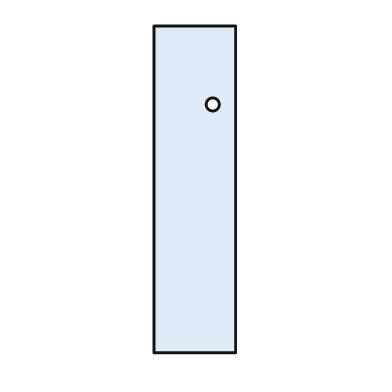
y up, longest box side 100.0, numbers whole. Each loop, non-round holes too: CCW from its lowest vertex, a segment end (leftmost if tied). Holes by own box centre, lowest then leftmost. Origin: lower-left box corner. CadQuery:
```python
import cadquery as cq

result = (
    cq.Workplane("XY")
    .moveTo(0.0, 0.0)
    .lineTo(25.0, 0.0)
    .lineTo(25.0, 100.0)
    .lineTo(0.0, 100.0)
    .close()
    .moveTo(18.0, 76.0)
    .circle(2.0)
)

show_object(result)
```